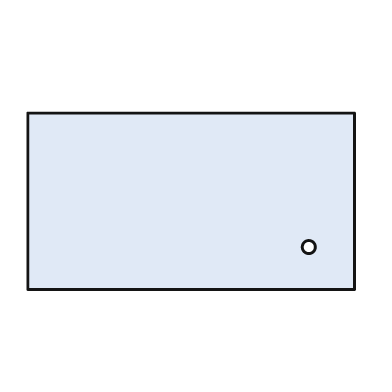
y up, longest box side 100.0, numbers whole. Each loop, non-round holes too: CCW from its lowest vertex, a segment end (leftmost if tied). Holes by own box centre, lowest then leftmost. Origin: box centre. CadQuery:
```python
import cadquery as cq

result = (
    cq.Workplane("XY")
    .moveTo(-50.0, -27.0)
    .lineTo(50.0, -27.0)
    .lineTo(50.0, 27.0)
    .lineTo(-50.0, 27.0)
    .close()
    .moveTo(36.0, -14.0)
    .circle(2.0)
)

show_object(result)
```